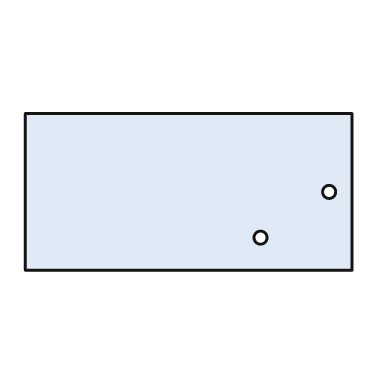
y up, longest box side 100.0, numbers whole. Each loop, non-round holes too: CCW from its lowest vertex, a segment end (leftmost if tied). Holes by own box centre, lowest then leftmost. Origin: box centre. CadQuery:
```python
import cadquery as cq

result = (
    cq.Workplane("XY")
    .moveTo(-50.0, -24.0)
    .lineTo(50.0, -24.0)
    .lineTo(50.0, 24.0)
    .lineTo(-50.0, 24.0)
    .close()
    .moveTo(22.0, -14.0)
    .circle(2.0)
    .moveTo(43.0, 0.0)
    .circle(2.0)
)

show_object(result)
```